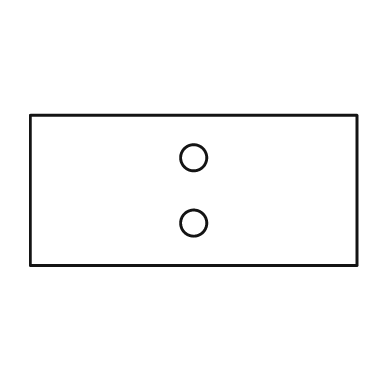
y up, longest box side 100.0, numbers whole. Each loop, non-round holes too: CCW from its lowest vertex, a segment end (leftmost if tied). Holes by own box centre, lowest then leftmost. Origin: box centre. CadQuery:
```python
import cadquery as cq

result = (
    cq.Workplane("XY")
    .moveTo(-50.0, -23.0)
    .lineTo(50.0, -23.0)
    .lineTo(50.0, 23.0)
    .lineTo(-50.0, 23.0)
    .close()
    .moveTo(0.0, -10.0)
    .circle(4.0)
    .moveTo(0.0, 10.0)
    .circle(4.0)
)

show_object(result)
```